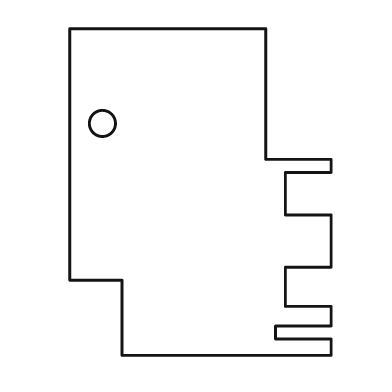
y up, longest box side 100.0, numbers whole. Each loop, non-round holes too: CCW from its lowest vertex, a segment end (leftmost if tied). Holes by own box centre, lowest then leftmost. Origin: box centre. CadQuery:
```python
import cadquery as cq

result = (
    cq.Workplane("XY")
    .moveTo(-24.0, -50.0)
    .lineTo(40.0, -50.0)
    .lineTo(40.0, -45.0)
    .lineTo(23.0, -45.0)
    .lineTo(23.0, -41.0)
    .lineTo(40.0, -41.0)
    .lineTo(40.0, -35.0)
    .lineTo(26.0, -35.0)
    .lineTo(26.0, -23.0)
    .lineTo(40.0, -23.0)
    .lineTo(40.0, -7.0)
    .lineTo(26.0, -7.0)
    .lineTo(26.0, 6.0)
    .lineTo(40.0, 6.0)
    .lineTo(40.0, 10.0)
    .lineTo(20.0, 10.0)
    .lineTo(20.0, 50.0)
    .lineTo(-40.0, 50.0)
    .lineTo(-40.0, -27.0)
    .lineTo(-24.0, -27.0)
    .close()
    .moveTo(-30.0, 21.0)
    .circle(4.0)
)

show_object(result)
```